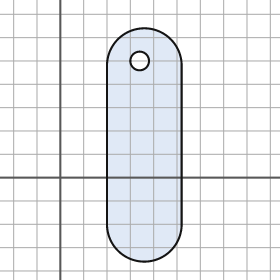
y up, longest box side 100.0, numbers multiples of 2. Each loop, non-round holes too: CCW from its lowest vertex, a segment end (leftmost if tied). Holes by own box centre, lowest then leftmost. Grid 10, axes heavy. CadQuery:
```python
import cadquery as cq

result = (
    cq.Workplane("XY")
    .moveTo(20.0, -20.0)
    .threePointArc((36.0, -36.0), (52.0, -20.0))
    .lineTo(52.0, 48.0)
    .threePointArc((36.0, 64.0), (20.0, 48.0))
    .close()
    .moveTo(34.0, 50.0)
    .circle(4.0)
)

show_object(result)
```